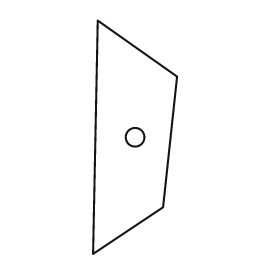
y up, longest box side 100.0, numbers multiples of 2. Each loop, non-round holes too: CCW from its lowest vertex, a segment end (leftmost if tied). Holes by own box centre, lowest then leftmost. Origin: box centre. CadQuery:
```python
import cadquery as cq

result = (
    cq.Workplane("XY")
    .moveTo(-18.0, -50.0)
    .lineTo(12.0, -30.0)
    .lineTo(18.0, 26.0)
    .lineTo(-16.0, 50.0)
    .close()
    .moveTo(0.0, 0.0)
    .circle(4.0)
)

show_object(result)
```